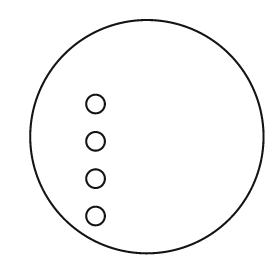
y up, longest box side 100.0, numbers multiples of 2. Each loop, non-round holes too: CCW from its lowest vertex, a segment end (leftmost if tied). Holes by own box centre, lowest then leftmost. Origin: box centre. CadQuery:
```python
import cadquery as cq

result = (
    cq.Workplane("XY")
    .moveTo(0.0, 0.0)
    .circle(50.0)
    .moveTo(-22.0, -34.0)
    .circle(4.0)
    .moveTo(-22.0, -18.0)
    .circle(4.0)
    .moveTo(-22.0, -2.0)
    .circle(4.0)
    .moveTo(-22.0, 14.0)
    .circle(4.0)
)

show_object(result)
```